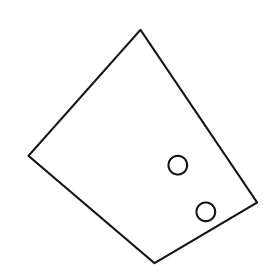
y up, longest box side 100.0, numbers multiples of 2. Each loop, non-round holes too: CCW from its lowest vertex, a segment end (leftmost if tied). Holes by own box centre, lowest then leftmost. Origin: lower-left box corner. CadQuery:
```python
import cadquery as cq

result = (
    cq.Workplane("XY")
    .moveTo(54.0, 0.0)
    .lineTo(98.0, 26.0)
    .lineTo(48.0, 100.0)
    .lineTo(0.0, 46.0)
    .close()
    .moveTo(76.0, 22.0)
    .circle(4.0)
    .moveTo(64.0, 42.0)
    .circle(4.0)
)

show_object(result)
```